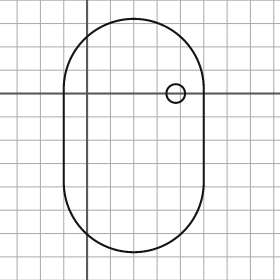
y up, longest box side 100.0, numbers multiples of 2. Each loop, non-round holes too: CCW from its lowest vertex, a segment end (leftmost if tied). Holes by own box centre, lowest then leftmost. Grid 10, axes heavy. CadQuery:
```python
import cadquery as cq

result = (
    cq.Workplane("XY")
    .moveTo(-10.0, -38.0)
    .threePointArc((20.0, -68.0), (50.0, -38.0))
    .lineTo(50.0, 2.0)
    .threePointArc((20.0, 32.0), (-10.0, 2.0))
    .close()
    .moveTo(38.0, 0.0)
    .circle(4.0)
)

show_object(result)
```